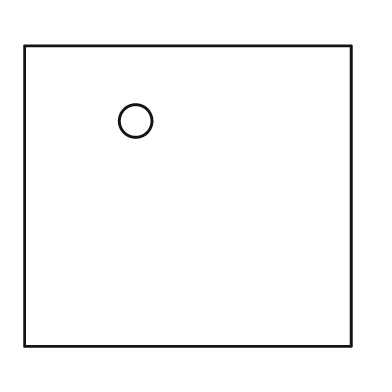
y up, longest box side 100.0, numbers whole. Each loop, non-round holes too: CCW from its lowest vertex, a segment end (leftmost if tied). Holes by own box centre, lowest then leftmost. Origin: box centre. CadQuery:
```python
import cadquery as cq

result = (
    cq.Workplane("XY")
    .moveTo(-50.0, -46.0)
    .lineTo(50.0, -46.0)
    .lineTo(50.0, 46.0)
    .lineTo(-50.0, 46.0)
    .close()
    .moveTo(-16.0, 23.0)
    .circle(5.0)
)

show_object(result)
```